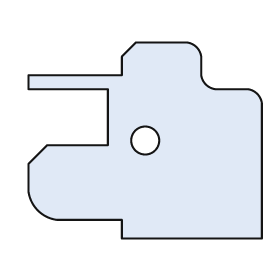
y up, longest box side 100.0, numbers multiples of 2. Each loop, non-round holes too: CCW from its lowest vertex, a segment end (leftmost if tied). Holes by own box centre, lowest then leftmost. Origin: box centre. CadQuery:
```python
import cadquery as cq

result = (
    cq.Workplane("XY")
    .moveTo(-10.0, -42.0)
    .lineTo(50.0, -42.0)
    .lineTo(50.0, 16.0)
    .threePointArc((48.0, 20.0), (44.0, 22.0))
    .lineTo(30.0, 22.0)
    .threePointArc((26.0, 24.0), (24.0, 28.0))
    .lineTo(24.0, 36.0)
    .threePointArc((22.0, 40.0), (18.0, 42.0))
    .lineTo(-4.0, 42.0)
    .lineTo(-10.0, 36.0)
    .lineTo(-10.0, 28.0)
    .lineTo(-50.0, 28.0)
    .lineTo(-50.0, 22.0)
    .lineTo(-16.0, 22.0)
    .lineTo(-16.0, -2.0)
    .lineTo(-42.0, -2.0)
    .lineTo(-50.0, -10.0)
    .lineTo(-50.0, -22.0)
    .threePointArc((-46.0, -30.0), (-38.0, -34.0))
    .lineTo(-10.0, -34.0)
    .close()
    .moveTo(0.0, 0.0)
    .circle(6.0)
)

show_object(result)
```